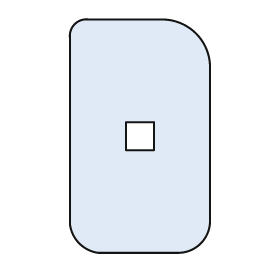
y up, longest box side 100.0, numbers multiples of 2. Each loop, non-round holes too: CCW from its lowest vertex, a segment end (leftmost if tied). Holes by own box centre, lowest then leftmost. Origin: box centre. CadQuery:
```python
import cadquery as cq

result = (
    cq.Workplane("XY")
    .moveTo(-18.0, -50.0)
    .lineTo(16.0, -50.0)
    .threePointArc((26.0, -46.0), (30.0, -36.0))
    .lineTo(30.0, 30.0)
    .threePointArc((24.0, 44.0), (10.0, 50.0))
    .lineTo(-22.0, 50.0)
    .threePointArc((-28.0, 48.0), (-30.0, 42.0))
    .lineTo(-30.0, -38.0)
    .threePointArc((-26.0, -46.0), (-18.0, -50.0))
    .close()
    .moveTo(-6.0, -6.0)
    .lineTo(6.0, -6.0)
    .lineTo(6.0, 6.0)
    .lineTo(-6.0, 6.0)
    .close()
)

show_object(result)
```